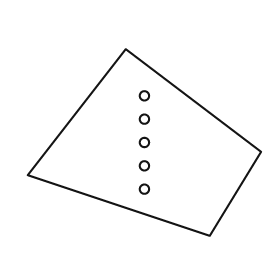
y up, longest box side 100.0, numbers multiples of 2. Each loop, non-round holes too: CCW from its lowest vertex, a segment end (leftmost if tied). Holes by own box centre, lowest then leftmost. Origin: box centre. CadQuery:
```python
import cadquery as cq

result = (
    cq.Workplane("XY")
    .moveTo(28.0, -40.0)
    .lineTo(50.0, -4.0)
    .lineTo(-8.0, 40.0)
    .lineTo(-50.0, -14.0)
    .close()
    .moveTo(0.0, -20.0)
    .circle(2.0)
    .moveTo(0.0, -10.0)
    .circle(2.0)
    .moveTo(0.0, 0.0)
    .circle(2.0)
    .moveTo(0.0, 10.0)
    .circle(2.0)
    .moveTo(0.0, 20.0)
    .circle(2.0)
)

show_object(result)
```